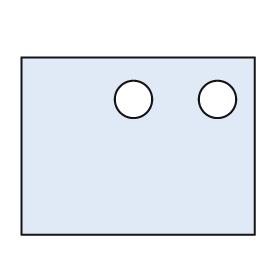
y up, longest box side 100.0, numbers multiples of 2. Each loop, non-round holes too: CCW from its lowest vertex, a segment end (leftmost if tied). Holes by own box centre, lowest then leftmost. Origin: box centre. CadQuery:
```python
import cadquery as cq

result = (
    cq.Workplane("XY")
    .moveTo(-50.0, -38.0)
    .lineTo(50.0, -38.0)
    .lineTo(50.0, 38.0)
    .lineTo(-50.0, 38.0)
    .close()
    .moveTo(-2.0, 20.0)
    .circle(8.0)
    .moveTo(34.0, 20.0)
    .circle(8.0)
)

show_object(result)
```